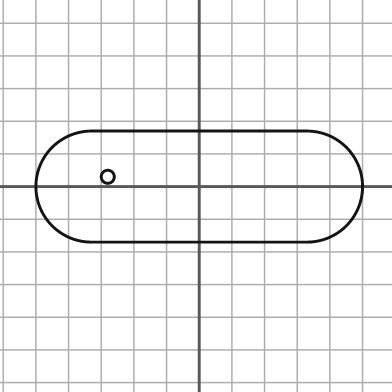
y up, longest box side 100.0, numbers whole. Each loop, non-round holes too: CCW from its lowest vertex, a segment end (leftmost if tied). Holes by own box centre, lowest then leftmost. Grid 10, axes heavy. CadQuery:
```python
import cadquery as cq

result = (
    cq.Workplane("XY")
    .moveTo(-33.0, -17.0)
    .lineTo(33.0, -17.0)
    .threePointArc((50.0, 0.0), (33.0, 17.0))
    .lineTo(-33.0, 17.0)
    .threePointArc((-50.0, 0.0), (-33.0, -17.0))
    .close()
    .moveTo(-28.0, 3.0)
    .circle(2.0)
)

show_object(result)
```